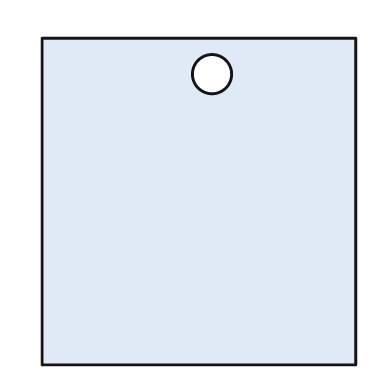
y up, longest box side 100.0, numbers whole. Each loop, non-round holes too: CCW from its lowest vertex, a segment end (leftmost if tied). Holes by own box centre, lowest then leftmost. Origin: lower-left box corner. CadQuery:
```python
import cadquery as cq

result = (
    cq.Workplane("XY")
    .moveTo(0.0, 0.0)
    .lineTo(96.0, 0.0)
    .lineTo(96.0, 100.0)
    .lineTo(0.0, 100.0)
    .close()
    .moveTo(52.0, 89.0)
    .circle(6.0)
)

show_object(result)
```